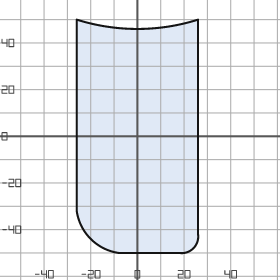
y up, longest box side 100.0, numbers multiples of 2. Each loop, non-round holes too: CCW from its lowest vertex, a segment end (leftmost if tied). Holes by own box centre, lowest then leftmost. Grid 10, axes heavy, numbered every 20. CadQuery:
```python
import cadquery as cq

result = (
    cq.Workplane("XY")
    .moveTo(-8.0, -50.0)
    .lineTo(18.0, -50.0)
    .threePointArc((24.0, -48.0), (26.0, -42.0))
    .lineTo(26.0, 50.0)
    .threePointArc((0.0, 46.0), (-26.0, 50.0))
    .lineTo(-26.0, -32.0)
    .threePointArc((-20.0, -44.0), (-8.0, -50.0))
    .close()
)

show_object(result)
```